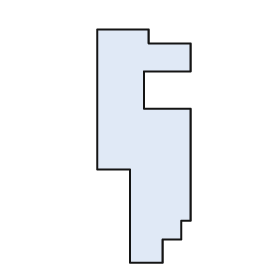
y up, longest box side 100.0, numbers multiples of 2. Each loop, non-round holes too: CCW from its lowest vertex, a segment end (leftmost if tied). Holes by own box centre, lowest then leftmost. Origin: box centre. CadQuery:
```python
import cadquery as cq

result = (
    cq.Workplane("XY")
    .moveTo(-6.0, -50.0)
    .lineTo(8.0, -50.0)
    .lineTo(8.0, -40.0)
    .lineTo(16.0, -40.0)
    .lineTo(16.0, -32.0)
    .lineTo(20.0, -32.0)
    .lineTo(20.0, 16.0)
    .lineTo(0.0, 16.0)
    .lineTo(0.0, 32.0)
    .lineTo(20.0, 32.0)
    .lineTo(20.0, 44.0)
    .lineTo(2.0, 44.0)
    .lineTo(2.0, 50.0)
    .lineTo(-20.0, 50.0)
    .lineTo(-20.0, -10.0)
    .lineTo(-6.0, -10.0)
    .close()
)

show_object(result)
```